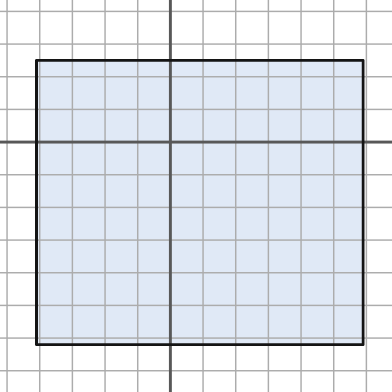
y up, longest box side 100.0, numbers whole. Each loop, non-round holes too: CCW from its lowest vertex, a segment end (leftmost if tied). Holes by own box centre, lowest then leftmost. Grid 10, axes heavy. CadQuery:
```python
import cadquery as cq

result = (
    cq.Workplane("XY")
    .moveTo(-41.0, -62.0)
    .lineTo(59.0, -62.0)
    .lineTo(59.0, 25.0)
    .lineTo(-41.0, 25.0)
    .close()
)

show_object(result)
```